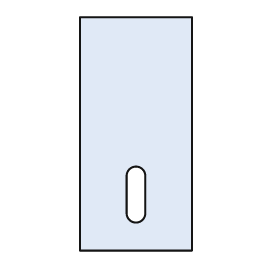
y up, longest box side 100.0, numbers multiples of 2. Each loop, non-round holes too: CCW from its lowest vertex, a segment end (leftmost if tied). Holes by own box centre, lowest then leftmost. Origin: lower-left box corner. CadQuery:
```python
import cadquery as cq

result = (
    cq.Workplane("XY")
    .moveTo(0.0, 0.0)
    .lineTo(48.0, 0.0)
    .lineTo(48.0, 100.0)
    .lineTo(0.0, 100.0)
    .close()
    .moveTo(20.0, 16.0)
    .threePointArc((24.0, 12.0), (28.0, 16.0))
    .lineTo(28.0, 32.0)
    .threePointArc((24.0, 36.0), (20.0, 32.0))
    .close()
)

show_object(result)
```